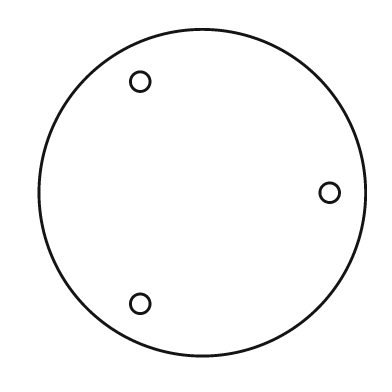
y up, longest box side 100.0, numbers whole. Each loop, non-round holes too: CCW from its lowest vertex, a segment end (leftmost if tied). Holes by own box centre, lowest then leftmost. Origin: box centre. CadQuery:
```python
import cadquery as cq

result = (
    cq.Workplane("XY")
    .moveTo(0.0, 0.0)
    .circle(50.0)
    .moveTo(-19.0, -34.0)
    .circle(3.0)
    .moveTo(39.0, 0.0)
    .circle(3.0)
    .moveTo(-19.0, 34.0)
    .circle(3.0)
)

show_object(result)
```